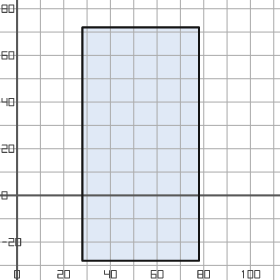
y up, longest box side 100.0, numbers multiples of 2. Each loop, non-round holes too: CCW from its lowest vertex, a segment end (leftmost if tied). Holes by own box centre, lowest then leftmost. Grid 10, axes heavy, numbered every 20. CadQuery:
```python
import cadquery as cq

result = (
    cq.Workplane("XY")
    .moveTo(28.0, -28.0)
    .lineTo(78.0, -28.0)
    .lineTo(78.0, 72.0)
    .lineTo(28.0, 72.0)
    .close()
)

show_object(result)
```